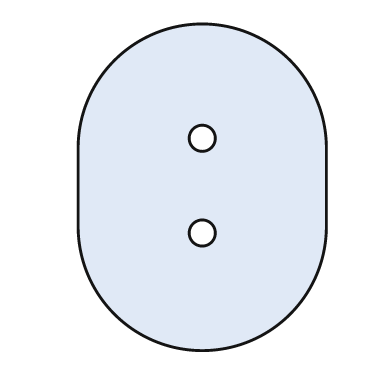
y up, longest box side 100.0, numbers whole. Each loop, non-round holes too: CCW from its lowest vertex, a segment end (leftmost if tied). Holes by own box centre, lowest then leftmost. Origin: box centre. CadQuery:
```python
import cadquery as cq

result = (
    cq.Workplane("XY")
    .moveTo(-38.0, -12.0)
    .threePointArc((0.0, -50.0), (38.0, -12.0))
    .lineTo(38.0, 12.0)
    .threePointArc((0.0, 50.0), (-38.0, 12.0))
    .close()
    .moveTo(0.0, -14.0)
    .circle(4.0)
    .moveTo(0.0, 15.0)
    .circle(4.0)
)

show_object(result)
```